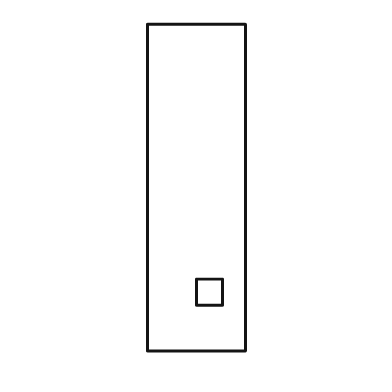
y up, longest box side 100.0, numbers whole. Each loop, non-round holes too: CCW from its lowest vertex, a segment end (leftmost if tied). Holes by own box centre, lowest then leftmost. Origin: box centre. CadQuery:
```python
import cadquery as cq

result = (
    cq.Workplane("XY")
    .moveTo(-15.0, -50.0)
    .lineTo(15.0, -50.0)
    .lineTo(15.0, 50.0)
    .lineTo(-15.0, 50.0)
    .close()
    .moveTo(0.0, -36.0)
    .lineTo(8.0, -36.0)
    .lineTo(8.0, -28.0)
    .lineTo(0.0, -28.0)
    .close()
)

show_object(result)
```